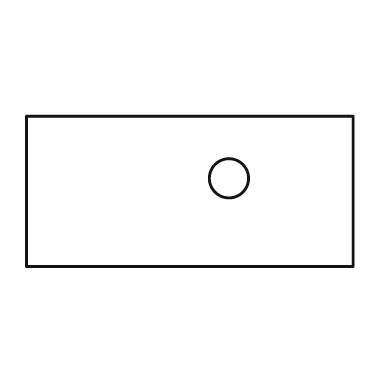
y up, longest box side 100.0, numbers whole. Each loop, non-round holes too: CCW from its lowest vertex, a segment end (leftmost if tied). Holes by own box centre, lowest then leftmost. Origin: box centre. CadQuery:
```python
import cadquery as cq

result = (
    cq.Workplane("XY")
    .moveTo(-50.0, -23.0)
    .lineTo(50.0, -23.0)
    .lineTo(50.0, 23.0)
    .lineTo(-50.0, 23.0)
    .close()
    .moveTo(12.0, 4.0)
    .circle(6.0)
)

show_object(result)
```